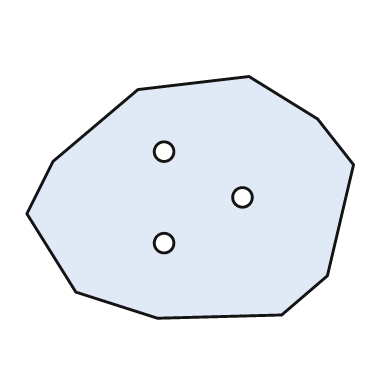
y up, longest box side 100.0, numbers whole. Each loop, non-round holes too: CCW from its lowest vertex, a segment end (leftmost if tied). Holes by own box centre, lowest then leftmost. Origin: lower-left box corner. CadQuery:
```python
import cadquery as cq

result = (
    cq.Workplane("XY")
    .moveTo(40.0, 0.0)
    .lineTo(78.0, 1.0)
    .lineTo(92.0, 13.0)
    .lineTo(100.0, 47.0)
    .lineTo(89.0, 61.0)
    .lineTo(68.0, 74.0)
    .lineTo(34.0, 70.0)
    .lineTo(8.0, 48.0)
    .lineTo(0.0, 32.0)
    .lineTo(15.0, 8.0)
    .close()
    .moveTo(42.0, 23.0)
    .circle(3.0)
    .moveTo(66.0, 37.0)
    .circle(3.0)
    .moveTo(42.0, 51.0)
    .circle(3.0)
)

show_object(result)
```